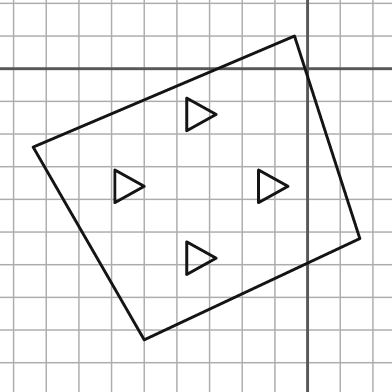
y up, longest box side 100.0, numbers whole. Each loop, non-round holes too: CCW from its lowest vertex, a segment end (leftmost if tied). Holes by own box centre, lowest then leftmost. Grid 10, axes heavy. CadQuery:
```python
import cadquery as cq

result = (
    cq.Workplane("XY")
    .moveTo(-50.0, -83.0)
    .lineTo(16.0, -52.0)
    .lineTo(-4.0, 10.0)
    .lineTo(-84.0, -24.0)
    .close()
    .moveTo(-37.0, -63.0)
    .lineTo(-28.0, -58.0)
    .lineTo(-37.0, -53.0)
    .close()
    .moveTo(-59.0, -41.0)
    .lineTo(-50.0, -36.0)
    .lineTo(-59.0, -31.0)
    .close()
    .moveTo(-15.0, -41.0)
    .lineTo(-6.0, -36.0)
    .lineTo(-15.0, -31.0)
    .close()
    .moveTo(-37.0, -19.0)
    .lineTo(-28.0, -14.0)
    .lineTo(-37.0, -9.0)
    .close()
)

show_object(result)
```